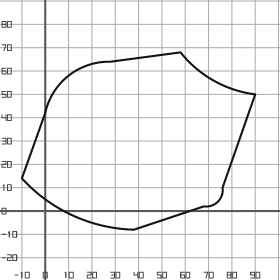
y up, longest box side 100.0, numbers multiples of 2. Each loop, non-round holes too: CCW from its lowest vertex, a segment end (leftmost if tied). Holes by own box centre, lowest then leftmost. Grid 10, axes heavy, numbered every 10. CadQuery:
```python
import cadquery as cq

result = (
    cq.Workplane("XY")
    .moveTo(38.0, -8.0)
    .lineTo(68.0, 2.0)
    .threePointArc((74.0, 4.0), (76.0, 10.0))
    .lineTo(90.0, 50.0)
    .threePointArc((72.0, 56.0), (58.0, 68.0))
    .lineTo(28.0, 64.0)
    .threePointArc((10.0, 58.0), (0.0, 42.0))
    .lineTo(-10.0, 14.0)
    .threePointArc((12.0, -2.0), (38.0, -8.0))
    .close()
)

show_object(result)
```